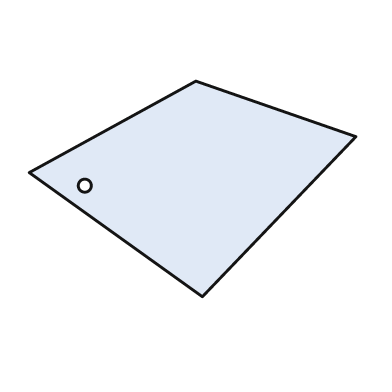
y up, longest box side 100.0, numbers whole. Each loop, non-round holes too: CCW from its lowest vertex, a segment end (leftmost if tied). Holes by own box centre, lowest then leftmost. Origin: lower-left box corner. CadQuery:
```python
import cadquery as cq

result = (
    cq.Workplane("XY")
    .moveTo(53.0, 0.0)
    .lineTo(100.0, 49.0)
    .lineTo(51.0, 66.0)
    .lineTo(0.0, 38.0)
    .close()
    .moveTo(17.0, 34.0)
    .circle(2.0)
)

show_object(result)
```